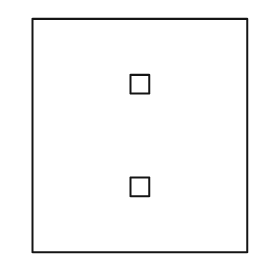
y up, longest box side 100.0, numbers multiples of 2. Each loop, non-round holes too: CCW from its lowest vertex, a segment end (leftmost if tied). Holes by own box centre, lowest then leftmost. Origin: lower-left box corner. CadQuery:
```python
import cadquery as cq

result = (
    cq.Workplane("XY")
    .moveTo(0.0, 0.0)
    .lineTo(92.0, 0.0)
    .lineTo(92.0, 100.0)
    .lineTo(0.0, 100.0)
    .close()
    .moveTo(42.0, 24.0)
    .lineTo(50.0, 24.0)
    .lineTo(50.0, 32.0)
    .lineTo(42.0, 32.0)
    .close()
    .moveTo(42.0, 68.0)
    .lineTo(50.0, 68.0)
    .lineTo(50.0, 76.0)
    .lineTo(42.0, 76.0)
    .close()
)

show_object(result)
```